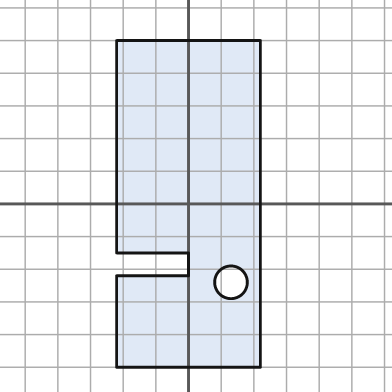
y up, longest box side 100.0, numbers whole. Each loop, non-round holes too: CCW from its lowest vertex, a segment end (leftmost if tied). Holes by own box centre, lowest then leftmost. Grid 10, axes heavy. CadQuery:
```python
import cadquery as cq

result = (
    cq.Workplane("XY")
    .moveTo(-22.0, -50.0)
    .lineTo(22.0, -50.0)
    .lineTo(22.0, 50.0)
    .lineTo(-22.0, 50.0)
    .lineTo(-22.0, -15.0)
    .lineTo(0.0, -15.0)
    .lineTo(0.0, -22.0)
    .lineTo(-22.0, -22.0)
    .close()
    .moveTo(13.0, -24.0)
    .circle(5.0)
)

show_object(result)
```